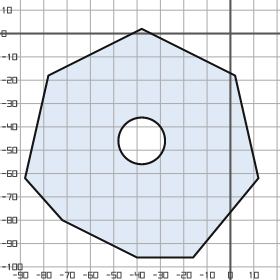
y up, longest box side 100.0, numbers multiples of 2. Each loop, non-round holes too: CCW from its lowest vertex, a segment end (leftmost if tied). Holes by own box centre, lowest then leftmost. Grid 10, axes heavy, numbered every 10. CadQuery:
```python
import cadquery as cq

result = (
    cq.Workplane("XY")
    .moveTo(-40.0, -96.0)
    .lineTo(-16.0, -96.0)
    .lineTo(12.0, -62.0)
    .lineTo(2.0, -18.0)
    .lineTo(-38.0, 2.0)
    .lineTo(-78.0, -18.0)
    .lineTo(-88.0, -62.0)
    .lineTo(-72.0, -80.0)
    .close()
    .moveTo(-38.0, -46.0)
    .circle(10.0)
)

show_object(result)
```